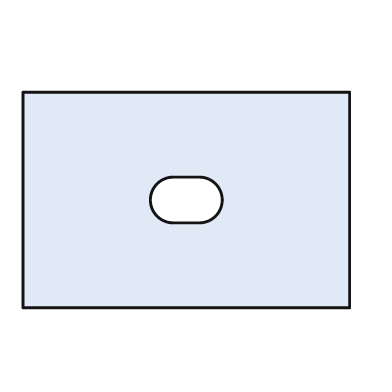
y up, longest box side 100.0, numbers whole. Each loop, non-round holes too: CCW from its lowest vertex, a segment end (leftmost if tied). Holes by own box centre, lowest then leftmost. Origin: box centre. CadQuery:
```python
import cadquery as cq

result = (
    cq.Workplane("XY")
    .moveTo(-50.0, -33.0)
    .lineTo(50.0, -33.0)
    .lineTo(50.0, 33.0)
    .lineTo(-50.0, 33.0)
    .close()
    .moveTo(-4.0, -7.0)
    .lineTo(4.0, -7.0)
    .threePointArc((11.0, 0.0), (4.0, 7.0))
    .lineTo(-4.0, 7.0)
    .threePointArc((-11.0, 0.0), (-4.0, -7.0))
    .close()
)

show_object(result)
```